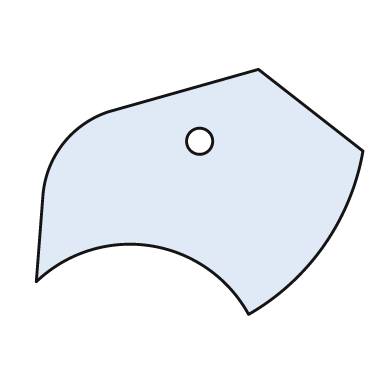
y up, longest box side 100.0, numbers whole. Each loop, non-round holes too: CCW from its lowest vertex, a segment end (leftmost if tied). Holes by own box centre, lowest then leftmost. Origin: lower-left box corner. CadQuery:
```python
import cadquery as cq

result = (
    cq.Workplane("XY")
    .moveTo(65.0, 0.0)
    .threePointArc((88.0, 21.0), (100.0, 50.0))
    .lineTo(68.0, 75.0)
    .lineTo(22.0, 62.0)
    .threePointArc((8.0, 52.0), (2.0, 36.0))
    .lineTo(0.0, 10.0)
    .threePointArc((35.0, 21.0), (65.0, 0.0))
    .close()
    .moveTo(50.0, 53.0)
    .circle(4.0)
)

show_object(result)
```